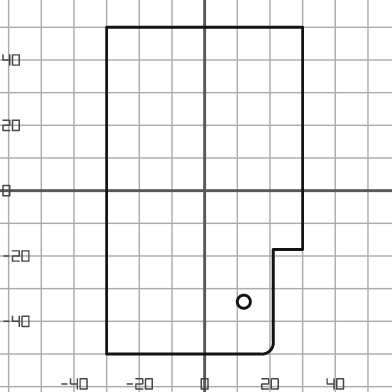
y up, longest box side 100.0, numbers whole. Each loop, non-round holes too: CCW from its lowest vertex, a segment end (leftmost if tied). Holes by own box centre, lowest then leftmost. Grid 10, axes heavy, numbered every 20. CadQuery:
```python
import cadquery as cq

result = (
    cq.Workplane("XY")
    .moveTo(-30.0, -50.0)
    .lineTo(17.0, -50.0)
    .threePointArc((20.0, -49.0), (21.0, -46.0))
    .lineTo(21.0, -18.0)
    .lineTo(30.0, -18.0)
    .lineTo(30.0, 50.0)
    .lineTo(-30.0, 50.0)
    .close()
    .moveTo(12.0, -34.0)
    .circle(2.0)
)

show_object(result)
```